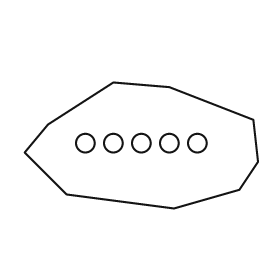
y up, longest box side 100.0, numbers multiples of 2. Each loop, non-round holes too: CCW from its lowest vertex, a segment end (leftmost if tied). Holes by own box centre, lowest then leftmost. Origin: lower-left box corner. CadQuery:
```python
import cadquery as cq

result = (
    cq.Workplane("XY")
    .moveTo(64.0, 0.0)
    .lineTo(92.0, 8.0)
    .lineTo(100.0, 20.0)
    .lineTo(98.0, 38.0)
    .lineTo(62.0, 52.0)
    .lineTo(38.0, 54.0)
    .lineTo(10.0, 36.0)
    .lineTo(0.0, 24.0)
    .lineTo(18.0, 6.0)
    .close()
    .moveTo(26.0, 28.0)
    .circle(4.0)
    .moveTo(38.0, 28.0)
    .circle(4.0)
    .moveTo(50.0, 28.0)
    .circle(4.0)
    .moveTo(62.0, 28.0)
    .circle(4.0)
    .moveTo(74.0, 28.0)
    .circle(4.0)
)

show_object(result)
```